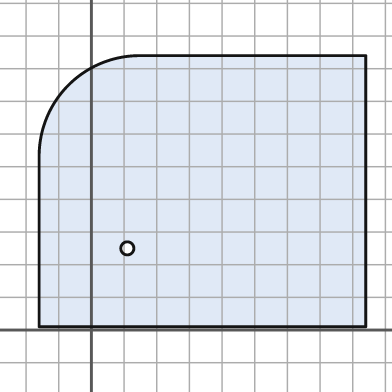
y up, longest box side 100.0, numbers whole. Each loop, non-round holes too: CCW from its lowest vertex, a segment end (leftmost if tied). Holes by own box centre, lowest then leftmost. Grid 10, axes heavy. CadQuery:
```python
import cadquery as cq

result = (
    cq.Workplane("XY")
    .moveTo(-16.0, 1.0)
    .lineTo(84.0, 1.0)
    .lineTo(84.0, 84.0)
    .lineTo(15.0, 84.0)
    .threePointArc((-7.0, 75.0), (-16.0, 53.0))
    .close()
    .moveTo(11.0, 25.0)
    .circle(2.0)
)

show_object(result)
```